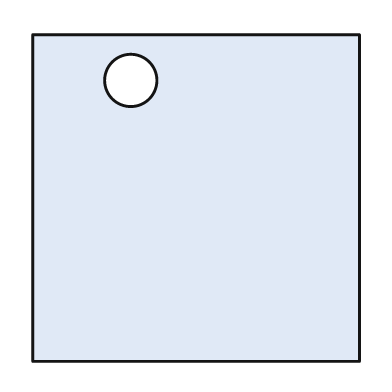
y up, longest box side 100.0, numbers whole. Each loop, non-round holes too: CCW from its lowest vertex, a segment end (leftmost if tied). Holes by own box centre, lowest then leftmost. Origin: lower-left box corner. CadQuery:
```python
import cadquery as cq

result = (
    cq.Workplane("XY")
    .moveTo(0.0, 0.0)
    .lineTo(100.0, 0.0)
    .lineTo(100.0, 100.0)
    .lineTo(0.0, 100.0)
    .close()
    .moveTo(30.0, 86.0)
    .circle(8.0)
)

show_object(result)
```